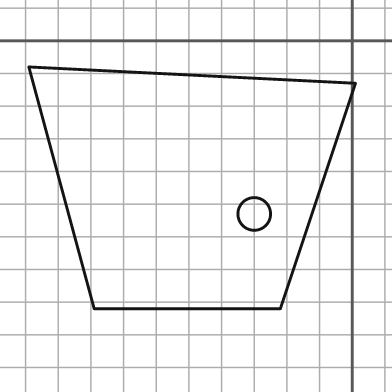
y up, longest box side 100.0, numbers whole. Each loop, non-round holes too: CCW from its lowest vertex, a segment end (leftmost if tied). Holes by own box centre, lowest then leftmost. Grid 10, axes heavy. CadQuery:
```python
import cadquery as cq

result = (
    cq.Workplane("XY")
    .moveTo(-79.0, -82.0)
    .lineTo(-22.0, -82.0)
    .lineTo(1.0, -13.0)
    .lineTo(-99.0, -8.0)
    .close()
    .moveTo(-30.0, -53.0)
    .circle(5.0)
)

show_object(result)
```